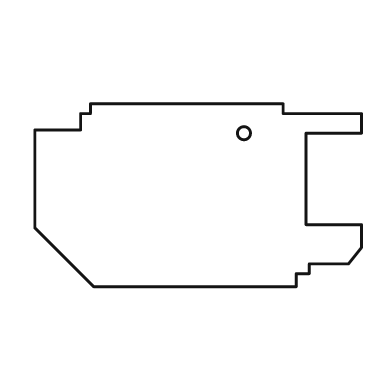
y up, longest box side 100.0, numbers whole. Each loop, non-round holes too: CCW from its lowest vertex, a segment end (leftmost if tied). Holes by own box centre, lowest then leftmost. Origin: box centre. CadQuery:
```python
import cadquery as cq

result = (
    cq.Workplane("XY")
    .moveTo(-32.0, -28.0)
    .lineTo(30.0, -28.0)
    .lineTo(30.0, -24.0)
    .lineTo(34.0, -24.0)
    .lineTo(34.0, -21.0)
    .lineTo(46.0, -21.0)
    .lineTo(50.0, -16.0)
    .lineTo(50.0, -9.0)
    .lineTo(33.0, -9.0)
    .lineTo(33.0, 19.0)
    .lineTo(50.0, 19.0)
    .lineTo(50.0, 25.0)
    .lineTo(26.0, 25.0)
    .lineTo(26.0, 28.0)
    .lineTo(-33.0, 28.0)
    .lineTo(-33.0, 25.0)
    .lineTo(-36.0, 25.0)
    .lineTo(-36.0, 20.0)
    .lineTo(-50.0, 20.0)
    .lineTo(-50.0, -10.0)
    .close()
    .moveTo(14.0, 19.0)
    .circle(2.0)
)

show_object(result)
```